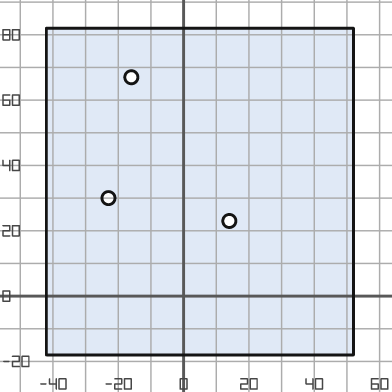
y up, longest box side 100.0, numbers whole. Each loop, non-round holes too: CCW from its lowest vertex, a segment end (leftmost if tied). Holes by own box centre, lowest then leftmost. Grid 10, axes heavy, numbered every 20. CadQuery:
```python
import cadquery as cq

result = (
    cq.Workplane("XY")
    .moveTo(-42.0, -18.0)
    .lineTo(52.0, -18.0)
    .lineTo(52.0, 82.0)
    .lineTo(-42.0, 82.0)
    .close()
    .moveTo(14.0, 23.0)
    .circle(2.0)
    .moveTo(-23.0, 30.0)
    .circle(2.0)
    .moveTo(-16.0, 67.0)
    .circle(2.0)
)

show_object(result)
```